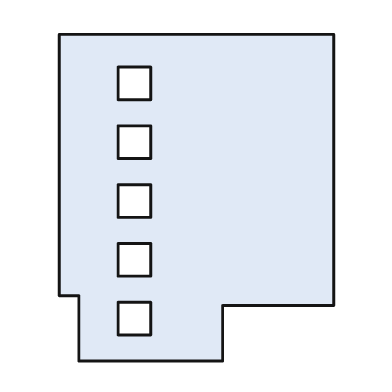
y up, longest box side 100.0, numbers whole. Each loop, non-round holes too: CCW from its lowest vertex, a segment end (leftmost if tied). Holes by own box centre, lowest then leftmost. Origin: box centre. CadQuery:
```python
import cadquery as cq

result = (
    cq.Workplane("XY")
    .moveTo(-36.0, -50.0)
    .lineTo(8.0, -50.0)
    .lineTo(8.0, -33.0)
    .lineTo(42.0, -33.0)
    .lineTo(42.0, 50.0)
    .lineTo(-42.0, 50.0)
    .lineTo(-42.0, -30.0)
    .lineTo(-36.0, -30.0)
    .close()
    .moveTo(-24.0, -42.0)
    .lineTo(-14.0, -42.0)
    .lineTo(-14.0, -32.0)
    .lineTo(-24.0, -32.0)
    .close()
    .moveTo(-24.0, -24.0)
    .lineTo(-14.0, -24.0)
    .lineTo(-14.0, -14.0)
    .lineTo(-24.0, -14.0)
    .close()
    .moveTo(-24.0, -6.0)
    .lineTo(-14.0, -6.0)
    .lineTo(-14.0, 4.0)
    .lineTo(-24.0, 4.0)
    .close()
    .moveTo(-24.0, 12.0)
    .lineTo(-14.0, 12.0)
    .lineTo(-14.0, 22.0)
    .lineTo(-24.0, 22.0)
    .close()
    .moveTo(-24.0, 30.0)
    .lineTo(-14.0, 30.0)
    .lineTo(-14.0, 40.0)
    .lineTo(-24.0, 40.0)
    .close()
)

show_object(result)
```